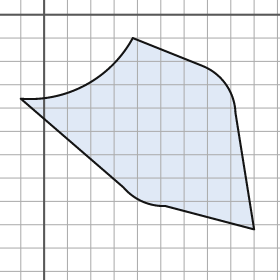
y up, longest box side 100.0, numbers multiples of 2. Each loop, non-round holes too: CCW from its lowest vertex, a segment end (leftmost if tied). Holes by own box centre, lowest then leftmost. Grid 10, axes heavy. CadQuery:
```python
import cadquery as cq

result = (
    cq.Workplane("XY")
    .moveTo(90.0, -92.0)
    .lineTo(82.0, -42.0)
    .threePointArc((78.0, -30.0), (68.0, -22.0))
    .lineTo(38.0, -10.0)
    .threePointArc((18.0, -30.0), (-10.0, -36.0))
    .lineTo(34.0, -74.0)
    .threePointArc((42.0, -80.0), (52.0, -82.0))
    .close()
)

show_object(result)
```